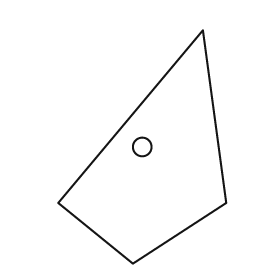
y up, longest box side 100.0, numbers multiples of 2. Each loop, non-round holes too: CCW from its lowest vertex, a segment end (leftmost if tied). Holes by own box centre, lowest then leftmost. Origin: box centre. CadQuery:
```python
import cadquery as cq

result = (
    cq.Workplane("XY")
    .moveTo(-4.0, -50.0)
    .lineTo(36.0, -24.0)
    .lineTo(26.0, 50.0)
    .lineTo(-36.0, -24.0)
    .close()
    .moveTo(0.0, 0.0)
    .circle(4.0)
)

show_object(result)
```